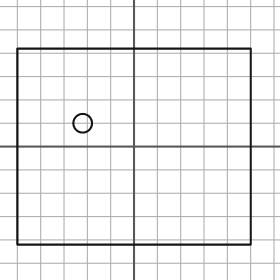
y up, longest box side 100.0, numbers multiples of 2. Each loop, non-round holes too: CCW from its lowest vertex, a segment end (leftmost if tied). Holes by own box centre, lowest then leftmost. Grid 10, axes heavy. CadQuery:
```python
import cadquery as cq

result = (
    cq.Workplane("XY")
    .moveTo(-50.0, -42.0)
    .lineTo(50.0, -42.0)
    .lineTo(50.0, 42.0)
    .lineTo(-50.0, 42.0)
    .close()
    .moveTo(-22.0, 10.0)
    .circle(4.0)
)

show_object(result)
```